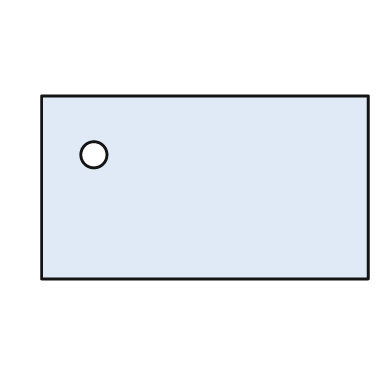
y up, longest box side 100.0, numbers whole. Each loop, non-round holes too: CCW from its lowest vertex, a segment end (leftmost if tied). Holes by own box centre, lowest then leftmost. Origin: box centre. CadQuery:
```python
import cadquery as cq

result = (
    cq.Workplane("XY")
    .moveTo(-50.0, -28.0)
    .lineTo(50.0, -28.0)
    .lineTo(50.0, 28.0)
    .lineTo(-50.0, 28.0)
    .close()
    .moveTo(-34.0, 10.0)
    .circle(4.0)
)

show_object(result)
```